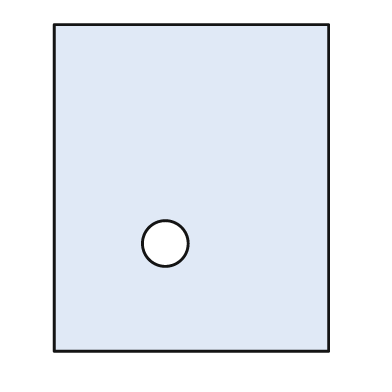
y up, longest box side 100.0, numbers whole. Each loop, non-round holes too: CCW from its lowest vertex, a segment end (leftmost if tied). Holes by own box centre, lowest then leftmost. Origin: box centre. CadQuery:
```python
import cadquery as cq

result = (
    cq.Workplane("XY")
    .moveTo(-42.0, -50.0)
    .lineTo(42.0, -50.0)
    .lineTo(42.0, 50.0)
    .lineTo(-42.0, 50.0)
    .close()
    .moveTo(-8.0, -17.0)
    .circle(7.0)
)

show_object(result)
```